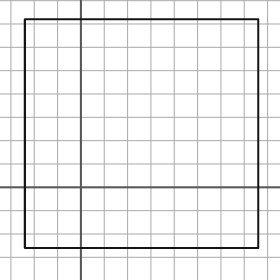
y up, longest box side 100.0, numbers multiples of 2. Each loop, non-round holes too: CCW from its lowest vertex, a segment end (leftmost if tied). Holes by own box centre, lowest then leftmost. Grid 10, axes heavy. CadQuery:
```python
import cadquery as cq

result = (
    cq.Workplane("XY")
    .moveTo(-24.0, -26.0)
    .lineTo(76.0, -26.0)
    .lineTo(76.0, 72.0)
    .lineTo(-24.0, 72.0)
    .close()
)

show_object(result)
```